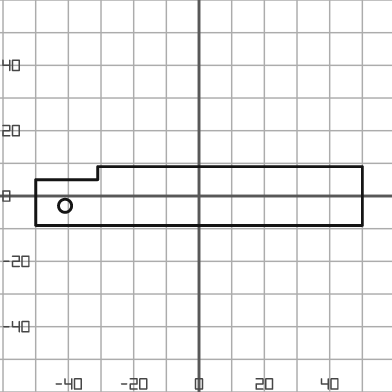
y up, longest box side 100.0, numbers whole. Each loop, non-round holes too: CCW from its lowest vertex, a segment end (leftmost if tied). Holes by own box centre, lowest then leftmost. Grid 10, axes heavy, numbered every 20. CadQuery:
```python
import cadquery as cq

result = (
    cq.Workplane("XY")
    .moveTo(-50.0, -9.0)
    .lineTo(50.0, -9.0)
    .lineTo(50.0, 9.0)
    .lineTo(-31.0, 9.0)
    .lineTo(-31.0, 5.0)
    .lineTo(-50.0, 5.0)
    .close()
    .moveTo(-41.0, -3.0)
    .circle(2.0)
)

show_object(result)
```